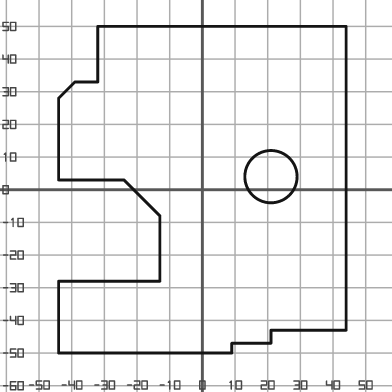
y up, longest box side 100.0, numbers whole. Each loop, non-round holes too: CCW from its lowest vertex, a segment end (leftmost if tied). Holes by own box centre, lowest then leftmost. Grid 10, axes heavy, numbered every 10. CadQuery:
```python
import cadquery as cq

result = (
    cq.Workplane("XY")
    .moveTo(-44.0, -50.0)
    .lineTo(9.0, -50.0)
    .lineTo(9.0, -47.0)
    .lineTo(21.0, -47.0)
    .lineTo(21.0, -43.0)
    .lineTo(44.0, -43.0)
    .lineTo(44.0, 50.0)
    .lineTo(-32.0, 50.0)
    .lineTo(-32.0, 33.0)
    .lineTo(-39.0, 33.0)
    .lineTo(-44.0, 28.0)
    .lineTo(-44.0, 3.0)
    .lineTo(-24.0, 3.0)
    .lineTo(-13.0, -8.0)
    .lineTo(-13.0, -28.0)
    .lineTo(-44.0, -28.0)
    .close()
    .moveTo(21.0, 4.0)
    .circle(8.0)
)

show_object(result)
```